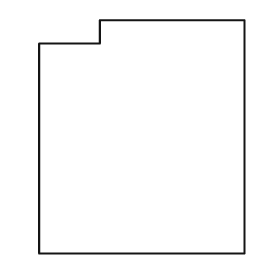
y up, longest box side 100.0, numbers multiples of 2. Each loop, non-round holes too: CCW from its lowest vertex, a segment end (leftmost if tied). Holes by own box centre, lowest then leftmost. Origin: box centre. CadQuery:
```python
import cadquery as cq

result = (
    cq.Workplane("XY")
    .moveTo(-44.0, -50.0)
    .lineTo(44.0, -50.0)
    .lineTo(44.0, 50.0)
    .lineTo(-18.0, 50.0)
    .lineTo(-18.0, 40.0)
    .lineTo(-44.0, 40.0)
    .close()
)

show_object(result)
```